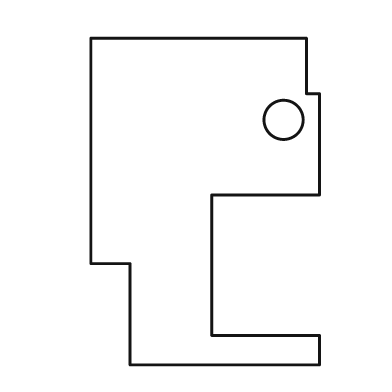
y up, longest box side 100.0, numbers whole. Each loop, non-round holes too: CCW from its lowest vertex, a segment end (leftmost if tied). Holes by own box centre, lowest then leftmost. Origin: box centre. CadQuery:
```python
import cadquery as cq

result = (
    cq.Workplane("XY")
    .moveTo(-23.0, -50.0)
    .lineTo(35.0, -50.0)
    .lineTo(35.0, -41.0)
    .lineTo(2.0, -41.0)
    .lineTo(2.0, 2.0)
    .lineTo(35.0, 2.0)
    .lineTo(35.0, 33.0)
    .lineTo(31.0, 33.0)
    .lineTo(31.0, 50.0)
    .lineTo(-35.0, 50.0)
    .lineTo(-35.0, -19.0)
    .lineTo(-23.0, -19.0)
    .close()
    .moveTo(24.0, 25.0)
    .circle(6.0)
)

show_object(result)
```